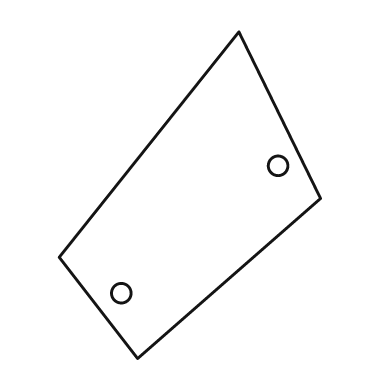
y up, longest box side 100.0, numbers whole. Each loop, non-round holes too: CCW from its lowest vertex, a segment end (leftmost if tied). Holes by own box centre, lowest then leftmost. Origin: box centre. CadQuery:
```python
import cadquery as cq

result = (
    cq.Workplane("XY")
    .moveTo(-16.0, -50.0)
    .lineTo(40.0, -1.0)
    .lineTo(15.0, 50.0)
    .lineTo(-40.0, -19.0)
    .close()
    .moveTo(-21.0, -30.0)
    .circle(3.0)
    .moveTo(27.0, 9.0)
    .circle(3.0)
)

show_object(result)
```